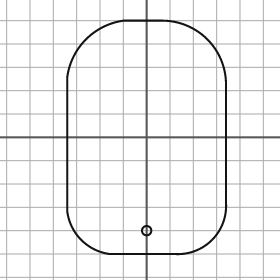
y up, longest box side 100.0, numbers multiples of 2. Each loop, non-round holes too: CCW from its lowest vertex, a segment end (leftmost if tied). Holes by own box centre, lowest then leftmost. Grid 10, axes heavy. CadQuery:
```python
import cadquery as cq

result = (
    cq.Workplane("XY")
    .moveTo(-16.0, -50.0)
    .lineTo(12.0, -50.0)
    .threePointArc((28.0, -44.0), (34.0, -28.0))
    .lineTo(34.0, 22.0)
    .threePointArc((26.0, 42.0), (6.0, 50.0))
    .lineTo(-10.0, 50.0)
    .threePointArc((-26.0, 42.0), (-34.0, 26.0))
    .lineTo(-34.0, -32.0)
    .threePointArc((-28.0, -44.0), (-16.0, -50.0))
    .close()
    .moveTo(0.0, -40.0)
    .circle(2.0)
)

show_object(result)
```